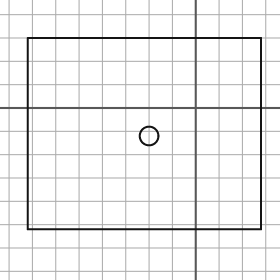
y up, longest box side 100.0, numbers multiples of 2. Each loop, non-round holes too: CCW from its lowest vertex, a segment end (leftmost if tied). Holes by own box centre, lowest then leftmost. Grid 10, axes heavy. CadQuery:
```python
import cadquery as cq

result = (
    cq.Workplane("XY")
    .moveTo(-72.0, -52.0)
    .lineTo(28.0, -52.0)
    .lineTo(28.0, 30.0)
    .lineTo(-72.0, 30.0)
    .close()
    .moveTo(-20.0, -12.0)
    .circle(4.0)
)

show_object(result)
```